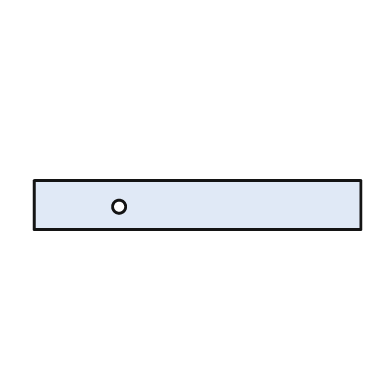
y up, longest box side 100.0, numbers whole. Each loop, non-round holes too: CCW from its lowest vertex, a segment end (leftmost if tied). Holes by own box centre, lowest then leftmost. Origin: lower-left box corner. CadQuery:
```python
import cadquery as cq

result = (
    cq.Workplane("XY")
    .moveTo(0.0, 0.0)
    .lineTo(100.0, 0.0)
    .lineTo(100.0, 15.0)
    .lineTo(0.0, 15.0)
    .close()
    .moveTo(26.0, 7.0)
    .circle(2.0)
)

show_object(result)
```